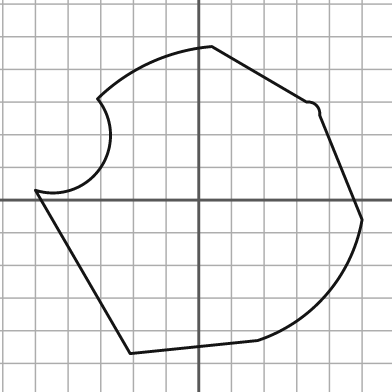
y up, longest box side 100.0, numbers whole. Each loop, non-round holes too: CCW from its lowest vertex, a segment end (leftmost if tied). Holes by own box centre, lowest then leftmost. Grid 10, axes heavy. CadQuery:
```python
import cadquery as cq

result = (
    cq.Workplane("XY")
    .moveTo(-21.0, -47.0)
    .lineTo(18.0, -43.0)
    .threePointArc((39.0, -29.0), (50.0, -6.0))
    .lineTo(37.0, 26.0)
    .threePointArc((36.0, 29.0), (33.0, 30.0))
    .lineTo(4.0, 47.0)
    .threePointArc((-15.0, 42.0), (-31.0, 31.0))
    .threePointArc((-30.0, 10.0), (-50.0, 3.0))
    .close()
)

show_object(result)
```